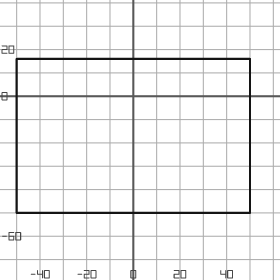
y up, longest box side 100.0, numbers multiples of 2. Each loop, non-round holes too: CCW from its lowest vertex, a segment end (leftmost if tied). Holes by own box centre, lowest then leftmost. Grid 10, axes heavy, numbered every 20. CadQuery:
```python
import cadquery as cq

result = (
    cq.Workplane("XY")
    .moveTo(-50.0, -50.0)
    .lineTo(50.0, -50.0)
    .lineTo(50.0, 16.0)
    .lineTo(-50.0, 16.0)
    .close()
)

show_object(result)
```